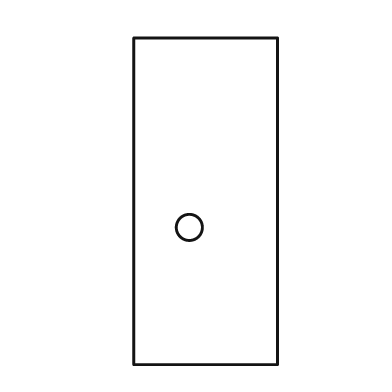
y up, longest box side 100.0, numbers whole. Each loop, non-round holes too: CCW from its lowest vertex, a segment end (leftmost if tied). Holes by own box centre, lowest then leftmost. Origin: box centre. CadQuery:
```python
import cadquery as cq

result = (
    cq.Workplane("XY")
    .moveTo(-22.0, -50.0)
    .lineTo(22.0, -50.0)
    .lineTo(22.0, 50.0)
    .lineTo(-22.0, 50.0)
    .close()
    .moveTo(-5.0, -8.0)
    .circle(4.0)
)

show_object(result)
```